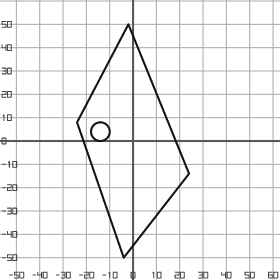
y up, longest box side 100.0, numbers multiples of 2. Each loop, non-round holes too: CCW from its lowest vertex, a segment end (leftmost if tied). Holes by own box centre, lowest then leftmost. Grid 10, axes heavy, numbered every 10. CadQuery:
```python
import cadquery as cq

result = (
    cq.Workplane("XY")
    .moveTo(-4.0, -50.0)
    .lineTo(24.0, -14.0)
    .lineTo(-2.0, 50.0)
    .lineTo(-24.0, 8.0)
    .close()
    .moveTo(-14.0, 4.0)
    .circle(4.0)
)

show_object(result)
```